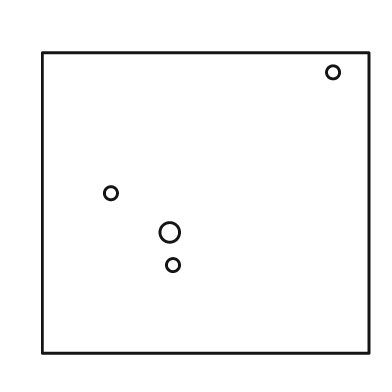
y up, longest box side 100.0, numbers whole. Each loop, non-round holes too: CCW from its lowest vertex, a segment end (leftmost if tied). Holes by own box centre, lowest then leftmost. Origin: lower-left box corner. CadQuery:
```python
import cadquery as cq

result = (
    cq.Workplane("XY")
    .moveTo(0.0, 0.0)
    .lineTo(100.0, 0.0)
    .lineTo(100.0, 92.0)
    .lineTo(0.0, 92.0)
    .close()
    .moveTo(40.0, 27.0)
    .circle(2.0)
    .moveTo(39.0, 37.0)
    .circle(3.0)
    .moveTo(21.0, 49.0)
    .circle(2.0)
    .moveTo(89.0, 86.0)
    .circle(2.0)
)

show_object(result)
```